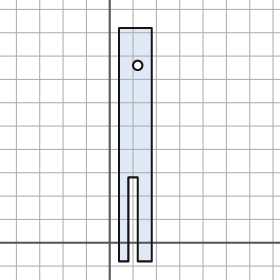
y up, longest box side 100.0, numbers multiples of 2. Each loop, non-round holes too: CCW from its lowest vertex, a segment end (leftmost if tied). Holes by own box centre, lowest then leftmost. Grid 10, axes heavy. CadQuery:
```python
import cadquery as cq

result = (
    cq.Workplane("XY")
    .moveTo(4.0, -8.0)
    .lineTo(8.0, -8.0)
    .lineTo(8.0, 28.0)
    .lineTo(12.0, 28.0)
    .lineTo(12.0, -8.0)
    .lineTo(18.0, -8.0)
    .lineTo(18.0, 92.0)
    .lineTo(4.0, 92.0)
    .close()
    .moveTo(12.0, 76.0)
    .circle(2.0)
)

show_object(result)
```